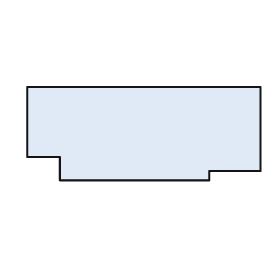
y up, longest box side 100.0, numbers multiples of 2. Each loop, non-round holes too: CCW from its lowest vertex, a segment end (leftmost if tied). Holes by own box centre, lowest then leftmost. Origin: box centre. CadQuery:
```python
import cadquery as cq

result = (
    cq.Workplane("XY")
    .moveTo(-36.0, -20.0)
    .lineTo(28.0, -20.0)
    .lineTo(28.0, -16.0)
    .lineTo(50.0, -16.0)
    .lineTo(50.0, 20.0)
    .lineTo(-50.0, 20.0)
    .lineTo(-50.0, -10.0)
    .lineTo(-36.0, -10.0)
    .close()
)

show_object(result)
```